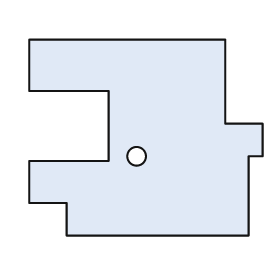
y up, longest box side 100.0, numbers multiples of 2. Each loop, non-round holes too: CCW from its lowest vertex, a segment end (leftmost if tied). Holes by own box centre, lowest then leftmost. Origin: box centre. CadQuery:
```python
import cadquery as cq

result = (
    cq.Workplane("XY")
    .moveTo(-34.0, -42.0)
    .lineTo(44.0, -42.0)
    .lineTo(44.0, -8.0)
    .lineTo(50.0, -8.0)
    .lineTo(50.0, 6.0)
    .lineTo(34.0, 6.0)
    .lineTo(34.0, 42.0)
    .lineTo(-50.0, 42.0)
    .lineTo(-50.0, 20.0)
    .lineTo(-16.0, 20.0)
    .lineTo(-16.0, -10.0)
    .lineTo(-50.0, -10.0)
    .lineTo(-50.0, -28.0)
    .lineTo(-34.0, -28.0)
    .close()
    .moveTo(-4.0, -8.0)
    .circle(4.0)
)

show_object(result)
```